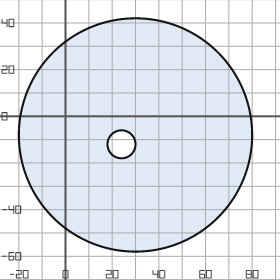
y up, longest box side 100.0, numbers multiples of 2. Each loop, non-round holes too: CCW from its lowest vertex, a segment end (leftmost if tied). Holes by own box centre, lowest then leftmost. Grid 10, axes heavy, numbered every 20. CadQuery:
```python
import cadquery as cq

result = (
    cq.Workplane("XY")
    .moveTo(30.0, -8.0)
    .circle(50.0)
    .moveTo(24.0, -12.0)
    .circle(6.0)
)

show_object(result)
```